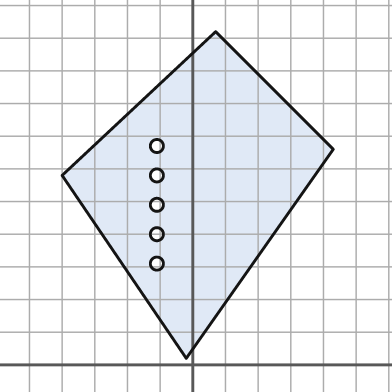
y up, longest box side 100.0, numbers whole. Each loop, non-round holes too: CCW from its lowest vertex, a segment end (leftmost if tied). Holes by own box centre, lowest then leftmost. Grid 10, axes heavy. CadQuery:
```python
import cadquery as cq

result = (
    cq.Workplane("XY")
    .moveTo(-2.0, 2.0)
    .lineTo(43.0, 66.0)
    .lineTo(7.0, 102.0)
    .lineTo(-40.0, 58.0)
    .close()
    .moveTo(-11.0, 31.0)
    .circle(2.0)
    .moveTo(-11.0, 40.0)
    .circle(2.0)
    .moveTo(-11.0, 49.0)
    .circle(2.0)
    .moveTo(-11.0, 58.0)
    .circle(2.0)
    .moveTo(-11.0, 67.0)
    .circle(2.0)
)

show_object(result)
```